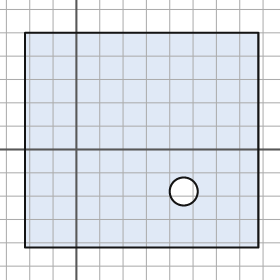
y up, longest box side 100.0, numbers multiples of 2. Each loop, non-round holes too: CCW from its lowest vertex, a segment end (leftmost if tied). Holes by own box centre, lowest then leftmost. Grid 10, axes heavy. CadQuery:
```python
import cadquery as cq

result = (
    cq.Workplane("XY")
    .moveTo(-22.0, -42.0)
    .lineTo(78.0, -42.0)
    .lineTo(78.0, 50.0)
    .lineTo(-22.0, 50.0)
    .close()
    .moveTo(46.0, -18.0)
    .circle(6.0)
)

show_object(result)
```